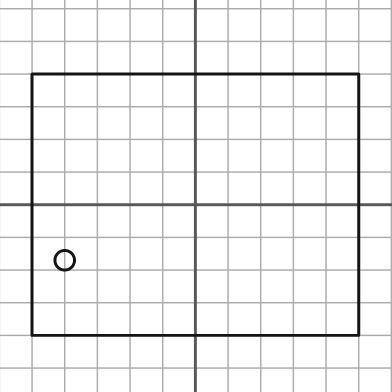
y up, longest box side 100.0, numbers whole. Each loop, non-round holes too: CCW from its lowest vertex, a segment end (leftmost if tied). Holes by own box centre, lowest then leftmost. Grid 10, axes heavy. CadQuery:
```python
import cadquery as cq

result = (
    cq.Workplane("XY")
    .moveTo(-50.0, -40.0)
    .lineTo(50.0, -40.0)
    .lineTo(50.0, 40.0)
    .lineTo(-50.0, 40.0)
    .close()
    .moveTo(-40.0, -17.0)
    .circle(3.0)
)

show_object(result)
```